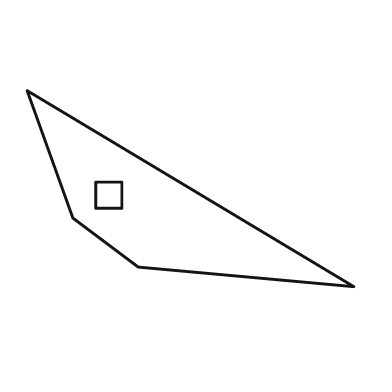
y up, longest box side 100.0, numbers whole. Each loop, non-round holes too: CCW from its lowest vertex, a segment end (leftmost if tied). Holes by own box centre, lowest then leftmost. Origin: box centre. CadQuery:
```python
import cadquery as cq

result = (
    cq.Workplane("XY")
    .moveTo(50.0, -30.0)
    .lineTo(-50.0, 30.0)
    .lineTo(-36.0, -9.0)
    .lineTo(-16.0, -24.0)
    .close()
    .moveTo(-29.0, -6.0)
    .lineTo(-21.0, -6.0)
    .lineTo(-21.0, 2.0)
    .lineTo(-29.0, 2.0)
    .close()
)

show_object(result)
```